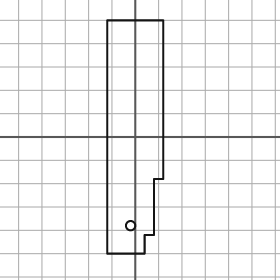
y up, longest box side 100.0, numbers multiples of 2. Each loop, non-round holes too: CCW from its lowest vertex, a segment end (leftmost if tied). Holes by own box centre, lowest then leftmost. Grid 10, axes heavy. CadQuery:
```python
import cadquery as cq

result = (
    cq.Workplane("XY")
    .moveTo(-12.0, -50.0)
    .lineTo(4.0, -50.0)
    .lineTo(4.0, -42.0)
    .lineTo(8.0, -42.0)
    .lineTo(8.0, -18.0)
    .lineTo(12.0, -18.0)
    .lineTo(12.0, 50.0)
    .lineTo(-12.0, 50.0)
    .close()
    .moveTo(-2.0, -38.0)
    .circle(2.0)
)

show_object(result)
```